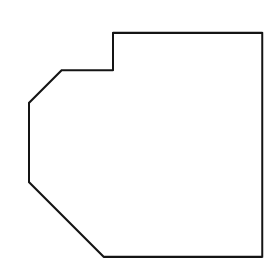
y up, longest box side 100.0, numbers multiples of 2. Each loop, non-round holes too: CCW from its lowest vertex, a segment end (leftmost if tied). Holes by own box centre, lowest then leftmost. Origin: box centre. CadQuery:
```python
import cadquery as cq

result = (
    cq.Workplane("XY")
    .moveTo(-18.0, -48.0)
    .lineTo(50.0, -48.0)
    .lineTo(50.0, 48.0)
    .lineTo(-14.0, 48.0)
    .lineTo(-14.0, 32.0)
    .lineTo(-36.0, 32.0)
    .lineTo(-50.0, 18.0)
    .lineTo(-50.0, -16.0)
    .close()
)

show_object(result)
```